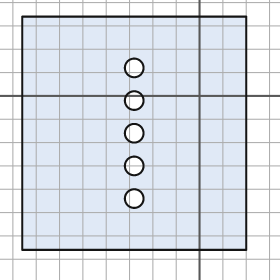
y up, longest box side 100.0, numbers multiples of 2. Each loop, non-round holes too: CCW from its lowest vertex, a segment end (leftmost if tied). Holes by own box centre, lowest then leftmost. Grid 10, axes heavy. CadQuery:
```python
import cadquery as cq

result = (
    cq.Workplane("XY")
    .moveTo(-76.0, -66.0)
    .lineTo(20.0, -66.0)
    .lineTo(20.0, 34.0)
    .lineTo(-76.0, 34.0)
    .close()
    .moveTo(-28.0, -44.0)
    .circle(4.0)
    .moveTo(-28.0, -30.0)
    .circle(4.0)
    .moveTo(-28.0, -16.0)
    .circle(4.0)
    .moveTo(-28.0, -2.0)
    .circle(4.0)
    .moveTo(-28.0, 12.0)
    .circle(4.0)
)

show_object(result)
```